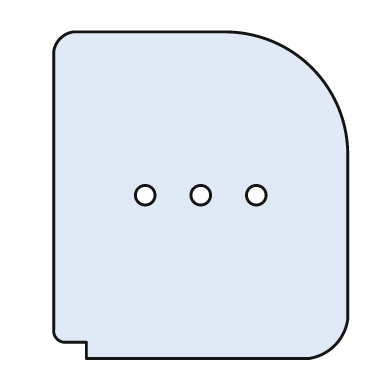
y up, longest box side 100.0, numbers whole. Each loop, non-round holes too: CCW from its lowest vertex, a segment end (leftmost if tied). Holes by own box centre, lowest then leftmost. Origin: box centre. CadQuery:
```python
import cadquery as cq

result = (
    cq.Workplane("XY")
    .moveTo(-35.0, -50.0)
    .lineTo(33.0, -50.0)
    .threePointArc((41.0, -46.0), (45.0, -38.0))
    .lineTo(45.0, 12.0)
    .threePointArc((34.0, 39.0), (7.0, 50.0))
    .lineTo(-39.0, 50.0)
    .threePointArc((-43.0, 48.0), (-45.0, 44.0))
    .lineTo(-45.0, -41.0)
    .threePointArc((-44.0, -44.0), (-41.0, -45.0))
    .lineTo(-35.0, -45.0)
    .close()
    .moveTo(-17.0, 0.0)
    .circle(3.0)
    .moveTo(0.0, 0.0)
    .circle(3.0)
    .moveTo(17.0, 0.0)
    .circle(3.0)
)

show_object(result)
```